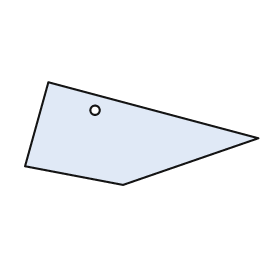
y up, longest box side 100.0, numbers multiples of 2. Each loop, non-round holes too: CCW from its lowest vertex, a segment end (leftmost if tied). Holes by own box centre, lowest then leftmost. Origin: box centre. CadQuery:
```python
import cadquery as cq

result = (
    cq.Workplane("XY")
    .moveTo(-8.0, -22.0)
    .lineTo(50.0, -2.0)
    .lineTo(-40.0, 22.0)
    .lineTo(-50.0, -14.0)
    .close()
    .moveTo(-20.0, 10.0)
    .circle(2.0)
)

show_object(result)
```